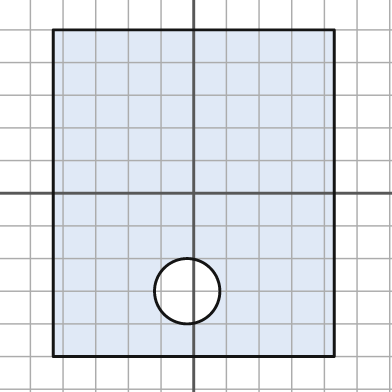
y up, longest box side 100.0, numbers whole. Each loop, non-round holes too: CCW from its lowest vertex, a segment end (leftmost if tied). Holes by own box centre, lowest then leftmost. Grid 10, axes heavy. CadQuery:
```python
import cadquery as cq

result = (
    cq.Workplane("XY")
    .moveTo(-43.0, -50.0)
    .lineTo(43.0, -50.0)
    .lineTo(43.0, 50.0)
    .lineTo(-43.0, 50.0)
    .close()
    .moveTo(-2.0, -30.0)
    .circle(10.0)
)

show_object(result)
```